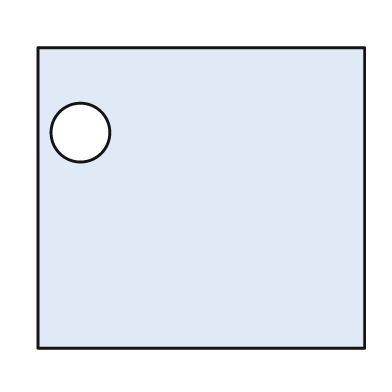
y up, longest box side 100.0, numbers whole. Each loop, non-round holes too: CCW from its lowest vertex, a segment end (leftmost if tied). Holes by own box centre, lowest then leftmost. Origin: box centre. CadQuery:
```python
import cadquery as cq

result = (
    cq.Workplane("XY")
    .moveTo(-50.0, -46.0)
    .lineTo(50.0, -46.0)
    .lineTo(50.0, 46.0)
    .lineTo(-50.0, 46.0)
    .close()
    .moveTo(-37.0, 20.0)
    .circle(9.0)
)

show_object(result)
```